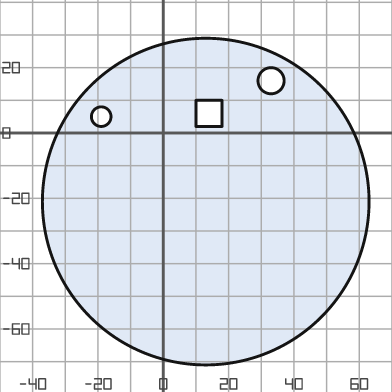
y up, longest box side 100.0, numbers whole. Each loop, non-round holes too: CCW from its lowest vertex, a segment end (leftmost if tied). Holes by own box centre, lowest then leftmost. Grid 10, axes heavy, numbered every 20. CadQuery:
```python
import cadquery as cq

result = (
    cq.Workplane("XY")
    .moveTo(13.0, -21.0)
    .circle(50.0)
    .moveTo(-19.0, 5.0)
    .circle(3.0)
    .moveTo(10.0, 2.0)
    .lineTo(18.0, 2.0)
    .lineTo(18.0, 10.0)
    .lineTo(10.0, 10.0)
    .close()
    .moveTo(33.0, 16.0)
    .circle(4.0)
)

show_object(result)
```